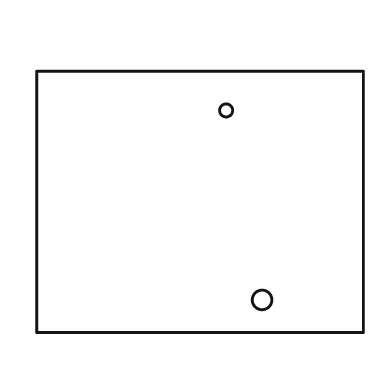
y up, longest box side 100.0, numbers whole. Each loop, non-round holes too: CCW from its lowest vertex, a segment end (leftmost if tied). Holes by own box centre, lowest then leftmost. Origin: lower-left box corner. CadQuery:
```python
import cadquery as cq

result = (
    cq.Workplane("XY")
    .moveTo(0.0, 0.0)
    .lineTo(100.0, 0.0)
    .lineTo(100.0, 80.0)
    .lineTo(0.0, 80.0)
    .close()
    .moveTo(69.0, 10.0)
    .circle(3.0)
    .moveTo(58.0, 68.0)
    .circle(2.0)
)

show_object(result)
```